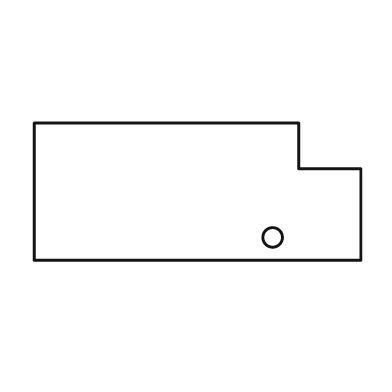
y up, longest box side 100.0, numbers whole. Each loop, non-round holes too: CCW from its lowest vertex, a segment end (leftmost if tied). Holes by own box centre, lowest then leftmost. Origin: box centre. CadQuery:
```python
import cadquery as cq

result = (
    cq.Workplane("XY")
    .moveTo(-50.0, -21.0)
    .lineTo(50.0, -21.0)
    .lineTo(50.0, 7.0)
    .lineTo(31.0, 7.0)
    .lineTo(31.0, 21.0)
    .lineTo(-50.0, 21.0)
    .close()
    .moveTo(23.0, -14.0)
    .circle(3.0)
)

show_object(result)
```